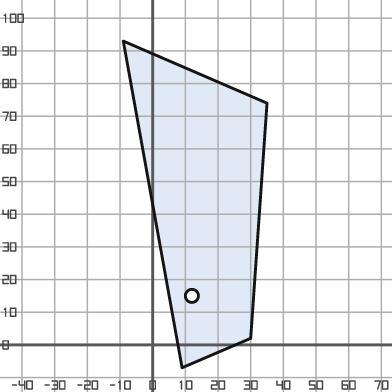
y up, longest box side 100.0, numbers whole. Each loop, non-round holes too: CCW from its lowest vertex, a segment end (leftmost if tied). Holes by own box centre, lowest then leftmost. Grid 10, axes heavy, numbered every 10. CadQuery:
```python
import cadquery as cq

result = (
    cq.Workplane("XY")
    .moveTo(9.0, -7.0)
    .lineTo(30.0, 2.0)
    .lineTo(35.0, 74.0)
    .lineTo(-9.0, 93.0)
    .close()
    .moveTo(12.0, 15.0)
    .circle(2.0)
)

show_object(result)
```